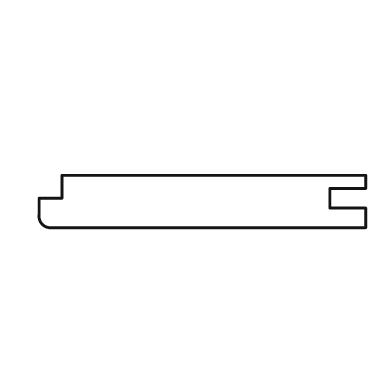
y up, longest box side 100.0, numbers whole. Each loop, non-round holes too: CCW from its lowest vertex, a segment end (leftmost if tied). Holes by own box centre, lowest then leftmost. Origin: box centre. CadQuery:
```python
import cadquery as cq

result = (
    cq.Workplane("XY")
    .moveTo(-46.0, -8.0)
    .lineTo(50.0, -8.0)
    .lineTo(50.0, -2.0)
    .lineTo(39.0, -2.0)
    .lineTo(39.0, 4.0)
    .lineTo(50.0, 4.0)
    .lineTo(50.0, 8.0)
    .lineTo(-43.0, 8.0)
    .lineTo(-43.0, 1.0)
    .lineTo(-50.0, 1.0)
    .lineTo(-50.0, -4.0)
    .threePointArc((-49.0, -7.0), (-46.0, -8.0))
    .close()
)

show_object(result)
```